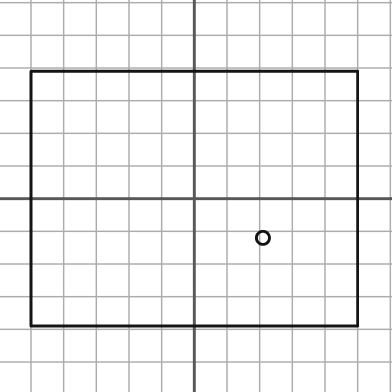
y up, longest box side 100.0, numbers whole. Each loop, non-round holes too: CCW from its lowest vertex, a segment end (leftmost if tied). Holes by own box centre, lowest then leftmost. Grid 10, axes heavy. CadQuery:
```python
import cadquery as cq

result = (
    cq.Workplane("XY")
    .moveTo(-50.0, -39.0)
    .lineTo(50.0, -39.0)
    .lineTo(50.0, 39.0)
    .lineTo(-50.0, 39.0)
    .close()
    .moveTo(21.0, -12.0)
    .circle(2.0)
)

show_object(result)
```